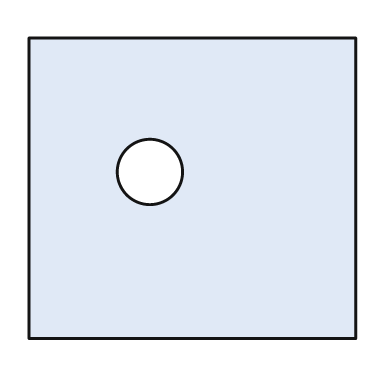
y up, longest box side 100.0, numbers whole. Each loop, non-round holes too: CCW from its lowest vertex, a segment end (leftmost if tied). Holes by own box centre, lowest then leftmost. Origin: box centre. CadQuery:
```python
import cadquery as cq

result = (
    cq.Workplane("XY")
    .moveTo(-50.0, -46.0)
    .lineTo(50.0, -46.0)
    .lineTo(50.0, 46.0)
    .lineTo(-50.0, 46.0)
    .close()
    .moveTo(-13.0, 5.0)
    .circle(10.0)
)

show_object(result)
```